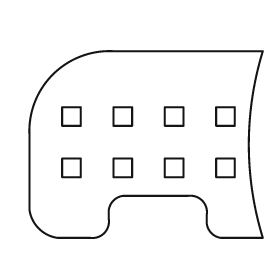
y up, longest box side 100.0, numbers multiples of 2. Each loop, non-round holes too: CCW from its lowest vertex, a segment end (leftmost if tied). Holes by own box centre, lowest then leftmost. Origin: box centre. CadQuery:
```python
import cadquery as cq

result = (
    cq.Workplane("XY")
    .moveTo(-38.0, -40.0)
    .lineTo(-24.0, -40.0)
    .threePointArc((-18.0, -38.0), (-16.0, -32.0))
    .lineTo(-16.0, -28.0)
    .threePointArc((-14.0, -24.0), (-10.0, -22.0))
    .lineTo(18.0, -22.0)
    .threePointArc((24.0, -24.0), (26.0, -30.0))
    .lineTo(26.0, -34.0)
    .threePointArc((28.0, -38.0), (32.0, -40.0))
    .lineTo(50.0, -40.0)
    .threePointArc((44.0, 0.0), (50.0, 40.0))
    .lineTo(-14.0, 40.0)
    .threePointArc((-40.0, 30.0), (-50.0, 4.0))
    .lineTo(-50.0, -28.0)
    .threePointArc((-46.0, -36.0), (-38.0, -40.0))
    .close()
    .moveTo(-36.0, -14.0)
    .lineTo(-28.0, -14.0)
    .lineTo(-28.0, -6.0)
    .lineTo(-36.0, -6.0)
    .close()
    .moveTo(-14.0, -14.0)
    .lineTo(-6.0, -14.0)
    .lineTo(-6.0, -6.0)
    .lineTo(-14.0, -6.0)
    .close()
    .moveTo(8.0, -14.0)
    .lineTo(16.0, -14.0)
    .lineTo(16.0, -6.0)
    .lineTo(8.0, -6.0)
    .close()
    .moveTo(30.0, -14.0)
    .lineTo(38.0, -14.0)
    .lineTo(38.0, -6.0)
    .lineTo(30.0, -6.0)
    .close()
    .moveTo(-36.0, 8.0)
    .lineTo(-28.0, 8.0)
    .lineTo(-28.0, 16.0)
    .lineTo(-36.0, 16.0)
    .close()
    .moveTo(-14.0, 8.0)
    .lineTo(-6.0, 8.0)
    .lineTo(-6.0, 16.0)
    .lineTo(-14.0, 16.0)
    .close()
    .moveTo(8.0, 8.0)
    .lineTo(16.0, 8.0)
    .lineTo(16.0, 16.0)
    .lineTo(8.0, 16.0)
    .close()
    .moveTo(30.0, 8.0)
    .lineTo(38.0, 8.0)
    .lineTo(38.0, 16.0)
    .lineTo(30.0, 16.0)
    .close()
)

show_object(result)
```